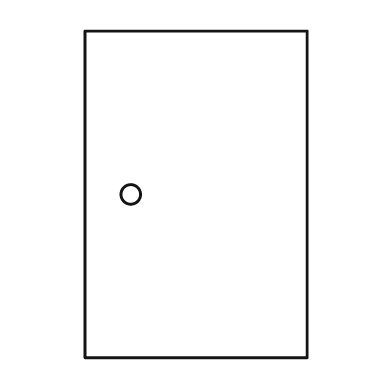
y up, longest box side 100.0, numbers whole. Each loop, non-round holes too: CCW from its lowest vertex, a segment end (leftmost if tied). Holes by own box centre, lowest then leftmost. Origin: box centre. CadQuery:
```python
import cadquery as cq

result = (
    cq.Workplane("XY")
    .moveTo(-34.0, -50.0)
    .lineTo(34.0, -50.0)
    .lineTo(34.0, 50.0)
    .lineTo(-34.0, 50.0)
    .close()
    .moveTo(-20.0, 0.0)
    .circle(3.0)
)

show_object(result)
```